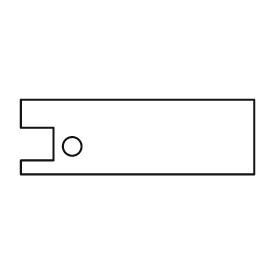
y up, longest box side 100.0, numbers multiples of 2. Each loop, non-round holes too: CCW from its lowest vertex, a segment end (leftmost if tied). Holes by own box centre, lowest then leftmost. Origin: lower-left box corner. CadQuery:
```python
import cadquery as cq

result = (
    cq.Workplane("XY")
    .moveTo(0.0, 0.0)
    .lineTo(100.0, 0.0)
    .lineTo(100.0, 32.0)
    .lineTo(0.0, 32.0)
    .lineTo(0.0, 20.0)
    .lineTo(14.0, 20.0)
    .lineTo(14.0, 6.0)
    .lineTo(0.0, 6.0)
    .close()
    .moveTo(22.0, 12.0)
    .circle(4.0)
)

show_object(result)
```